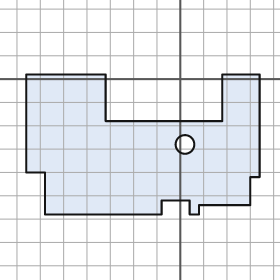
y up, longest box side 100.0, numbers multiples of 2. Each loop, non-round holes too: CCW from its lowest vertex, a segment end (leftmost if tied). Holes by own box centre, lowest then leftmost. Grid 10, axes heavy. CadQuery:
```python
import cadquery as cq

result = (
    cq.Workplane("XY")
    .moveTo(-58.0, -58.0)
    .lineTo(-8.0, -58.0)
    .lineTo(-8.0, -52.0)
    .lineTo(4.0, -52.0)
    .lineTo(4.0, -58.0)
    .lineTo(8.0, -58.0)
    .lineTo(8.0, -54.0)
    .lineTo(30.0, -54.0)
    .lineTo(30.0, -42.0)
    .lineTo(34.0, -42.0)
    .lineTo(34.0, 2.0)
    .lineTo(18.0, 2.0)
    .lineTo(18.0, -18.0)
    .lineTo(-32.0, -18.0)
    .lineTo(-32.0, 2.0)
    .lineTo(-66.0, 2.0)
    .lineTo(-66.0, -40.0)
    .lineTo(-58.0, -40.0)
    .close()
    .moveTo(2.0, -28.0)
    .circle(4.0)
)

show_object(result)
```